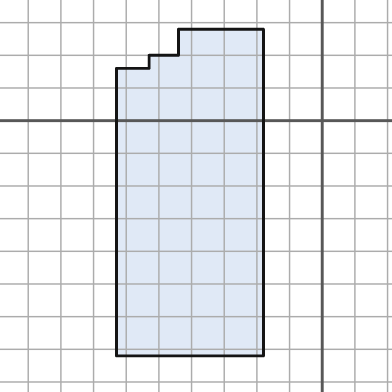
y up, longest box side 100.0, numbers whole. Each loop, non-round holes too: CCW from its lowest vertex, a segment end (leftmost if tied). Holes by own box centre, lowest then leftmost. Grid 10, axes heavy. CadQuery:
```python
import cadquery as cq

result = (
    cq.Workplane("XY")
    .moveTo(-63.0, -72.0)
    .lineTo(-18.0, -72.0)
    .lineTo(-18.0, 28.0)
    .lineTo(-44.0, 28.0)
    .lineTo(-44.0, 20.0)
    .lineTo(-53.0, 20.0)
    .lineTo(-53.0, 16.0)
    .lineTo(-63.0, 16.0)
    .close()
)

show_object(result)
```